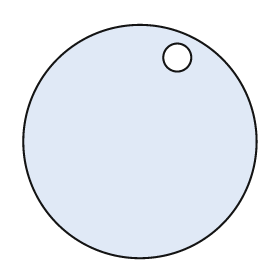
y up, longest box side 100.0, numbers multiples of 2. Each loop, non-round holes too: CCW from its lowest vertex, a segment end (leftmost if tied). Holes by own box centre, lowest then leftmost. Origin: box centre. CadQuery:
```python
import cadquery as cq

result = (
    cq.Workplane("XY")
    .moveTo(0.0, 0.0)
    .circle(50.0)
    .moveTo(16.0, 36.0)
    .circle(6.0)
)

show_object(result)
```